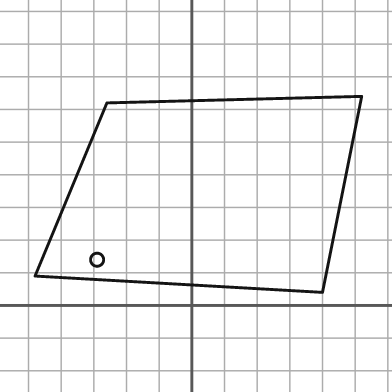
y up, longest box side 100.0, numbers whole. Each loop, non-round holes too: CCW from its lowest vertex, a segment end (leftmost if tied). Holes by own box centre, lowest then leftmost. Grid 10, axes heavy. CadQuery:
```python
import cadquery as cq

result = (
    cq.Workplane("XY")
    .moveTo(40.0, 4.0)
    .lineTo(52.0, 64.0)
    .lineTo(-26.0, 62.0)
    .lineTo(-48.0, 9.0)
    .close()
    .moveTo(-29.0, 14.0)
    .circle(2.0)
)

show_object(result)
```